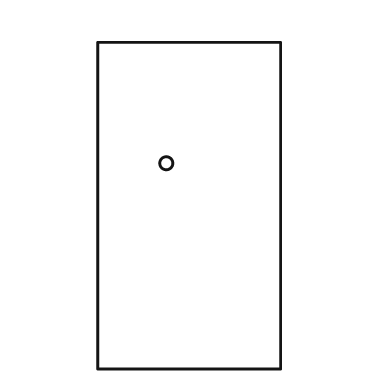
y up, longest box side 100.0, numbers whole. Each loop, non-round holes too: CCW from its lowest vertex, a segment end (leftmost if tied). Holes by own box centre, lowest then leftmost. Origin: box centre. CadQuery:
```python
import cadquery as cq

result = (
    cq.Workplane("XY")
    .moveTo(-28.0, -50.0)
    .lineTo(28.0, -50.0)
    .lineTo(28.0, 50.0)
    .lineTo(-28.0, 50.0)
    .close()
    .moveTo(-7.0, 13.0)
    .circle(2.0)
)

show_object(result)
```